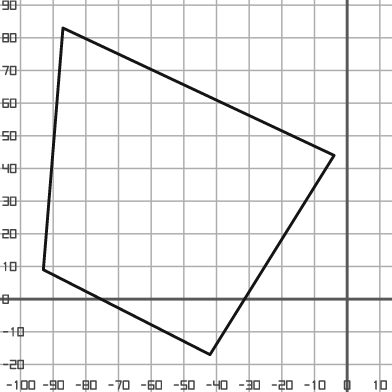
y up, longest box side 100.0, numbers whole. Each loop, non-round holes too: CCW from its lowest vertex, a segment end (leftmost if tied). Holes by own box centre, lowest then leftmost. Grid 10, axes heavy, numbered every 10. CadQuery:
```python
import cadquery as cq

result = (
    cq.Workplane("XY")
    .moveTo(-42.0, -17.0)
    .lineTo(-4.0, 44.0)
    .lineTo(-87.0, 83.0)
    .lineTo(-93.0, 9.0)
    .close()
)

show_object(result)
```